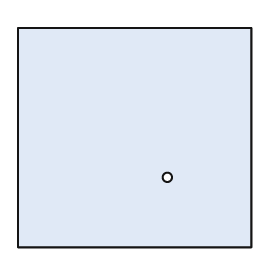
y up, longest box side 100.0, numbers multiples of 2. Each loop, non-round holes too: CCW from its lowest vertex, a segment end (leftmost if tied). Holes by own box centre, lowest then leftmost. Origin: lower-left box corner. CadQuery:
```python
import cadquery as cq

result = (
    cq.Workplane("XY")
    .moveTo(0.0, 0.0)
    .lineTo(100.0, 0.0)
    .lineTo(100.0, 94.0)
    .lineTo(0.0, 94.0)
    .close()
    .moveTo(64.0, 30.0)
    .circle(2.0)
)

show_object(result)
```